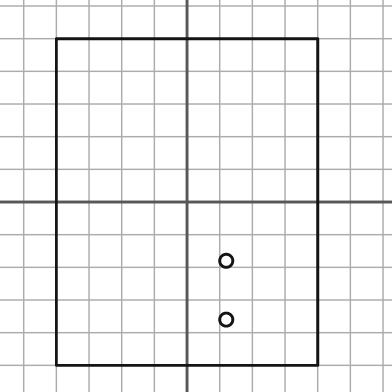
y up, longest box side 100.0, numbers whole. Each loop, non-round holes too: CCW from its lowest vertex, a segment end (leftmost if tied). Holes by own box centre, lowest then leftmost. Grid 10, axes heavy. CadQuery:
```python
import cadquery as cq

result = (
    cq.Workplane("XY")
    .moveTo(-40.0, -50.0)
    .lineTo(40.0, -50.0)
    .lineTo(40.0, 50.0)
    .lineTo(-40.0, 50.0)
    .close()
    .moveTo(12.0, -36.0)
    .circle(2.0)
    .moveTo(12.0, -18.0)
    .circle(2.0)
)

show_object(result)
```